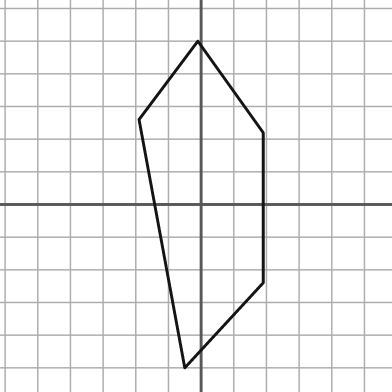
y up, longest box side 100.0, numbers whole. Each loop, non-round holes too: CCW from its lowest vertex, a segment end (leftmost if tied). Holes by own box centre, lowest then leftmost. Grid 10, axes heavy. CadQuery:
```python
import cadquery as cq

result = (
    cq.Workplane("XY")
    .moveTo(-5.0, -50.0)
    .lineTo(19.0, -24.0)
    .lineTo(19.0, 22.0)
    .lineTo(-1.0, 50.0)
    .lineTo(-19.0, 26.0)
    .close()
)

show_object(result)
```